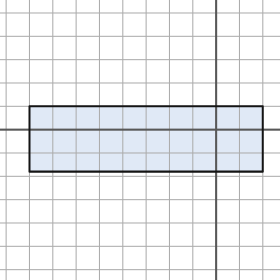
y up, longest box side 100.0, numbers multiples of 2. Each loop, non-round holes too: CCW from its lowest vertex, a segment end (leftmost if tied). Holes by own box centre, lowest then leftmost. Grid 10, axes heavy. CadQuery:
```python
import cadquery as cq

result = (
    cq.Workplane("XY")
    .moveTo(-80.0, -18.0)
    .lineTo(20.0, -18.0)
    .lineTo(20.0, 10.0)
    .lineTo(-80.0, 10.0)
    .close()
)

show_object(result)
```